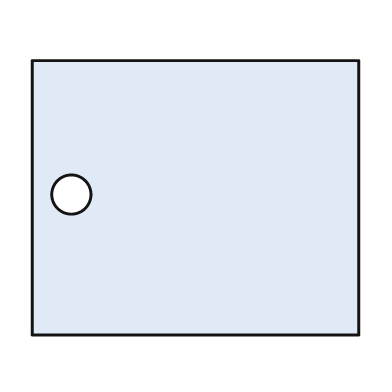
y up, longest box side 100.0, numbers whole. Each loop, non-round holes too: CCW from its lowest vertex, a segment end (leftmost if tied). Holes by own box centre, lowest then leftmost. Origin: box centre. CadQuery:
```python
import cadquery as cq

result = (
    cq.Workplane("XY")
    .moveTo(-50.0, -42.0)
    .lineTo(50.0, -42.0)
    .lineTo(50.0, 42.0)
    .lineTo(-50.0, 42.0)
    .close()
    .moveTo(-38.0, 1.0)
    .circle(6.0)
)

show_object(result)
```